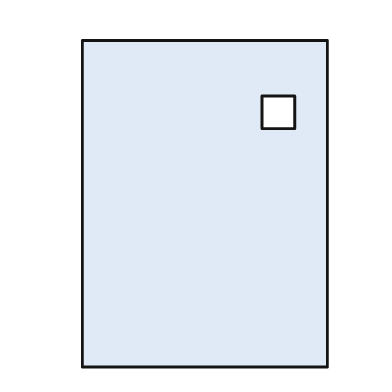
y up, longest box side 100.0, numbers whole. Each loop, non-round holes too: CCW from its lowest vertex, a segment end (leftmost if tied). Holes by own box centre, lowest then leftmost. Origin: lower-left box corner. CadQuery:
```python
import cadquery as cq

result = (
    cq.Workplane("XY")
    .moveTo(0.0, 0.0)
    .lineTo(75.0, 0.0)
    .lineTo(75.0, 100.0)
    .lineTo(0.0, 100.0)
    .close()
    .moveTo(55.0, 73.0)
    .lineTo(65.0, 73.0)
    .lineTo(65.0, 83.0)
    .lineTo(55.0, 83.0)
    .close()
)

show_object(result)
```